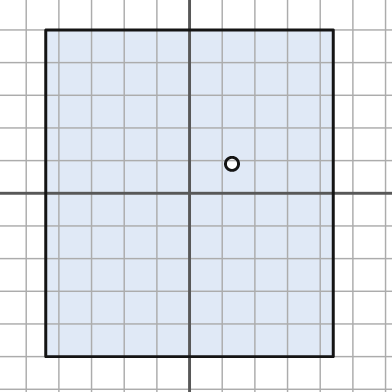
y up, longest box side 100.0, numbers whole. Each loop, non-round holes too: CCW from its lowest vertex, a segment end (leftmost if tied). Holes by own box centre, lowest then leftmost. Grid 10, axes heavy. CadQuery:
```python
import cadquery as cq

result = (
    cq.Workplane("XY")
    .moveTo(-44.0, -50.0)
    .lineTo(44.0, -50.0)
    .lineTo(44.0, 50.0)
    .lineTo(-44.0, 50.0)
    .close()
    .moveTo(13.0, 9.0)
    .circle(2.0)
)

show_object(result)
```